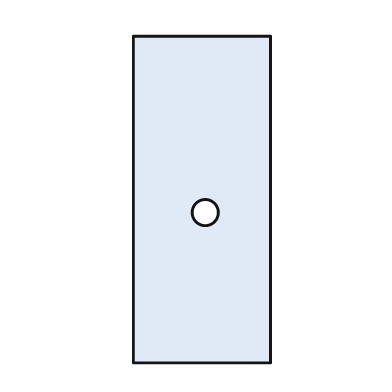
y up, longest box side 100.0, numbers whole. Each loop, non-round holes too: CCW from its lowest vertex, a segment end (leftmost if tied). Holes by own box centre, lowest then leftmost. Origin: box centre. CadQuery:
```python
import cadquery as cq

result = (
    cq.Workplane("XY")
    .moveTo(-21.0, -50.0)
    .lineTo(21.0, -50.0)
    .lineTo(21.0, 50.0)
    .lineTo(-21.0, 50.0)
    .close()
    .moveTo(1.0, -4.0)
    .circle(4.0)
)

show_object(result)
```